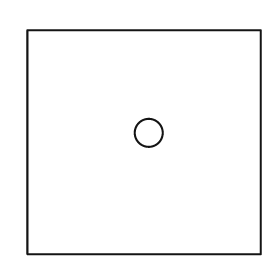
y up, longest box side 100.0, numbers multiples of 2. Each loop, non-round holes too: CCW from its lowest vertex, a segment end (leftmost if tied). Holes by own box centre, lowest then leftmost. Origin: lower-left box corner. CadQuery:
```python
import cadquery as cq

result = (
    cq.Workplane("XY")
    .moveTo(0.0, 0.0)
    .lineTo(100.0, 0.0)
    .lineTo(100.0, 96.0)
    .lineTo(0.0, 96.0)
    .close()
    .moveTo(52.0, 52.0)
    .circle(6.0)
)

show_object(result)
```